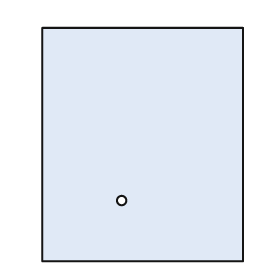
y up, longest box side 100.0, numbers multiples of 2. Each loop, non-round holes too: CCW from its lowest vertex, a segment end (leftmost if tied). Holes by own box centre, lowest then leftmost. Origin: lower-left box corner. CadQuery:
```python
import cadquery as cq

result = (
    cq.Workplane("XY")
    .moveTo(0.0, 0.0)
    .lineTo(86.0, 0.0)
    .lineTo(86.0, 100.0)
    .lineTo(0.0, 100.0)
    .close()
    .moveTo(34.0, 26.0)
    .circle(2.0)
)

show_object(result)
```